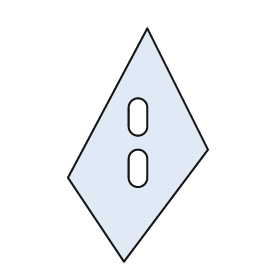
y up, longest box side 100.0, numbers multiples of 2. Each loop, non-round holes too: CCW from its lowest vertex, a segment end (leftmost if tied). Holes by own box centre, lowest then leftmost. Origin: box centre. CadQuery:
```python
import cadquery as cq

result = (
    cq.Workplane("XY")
    .moveTo(-6.0, -50.0)
    .lineTo(30.0, -2.0)
    .lineTo(4.0, 50.0)
    .lineTo(-30.0, -14.0)
    .close()
    .moveTo(-4.0, -14.0)
    .threePointArc((0.0, -18.0), (4.0, -14.0))
    .lineTo(4.0, -6.0)
    .threePointArc((0.0, -2.0), (-4.0, -6.0))
    .close()
    .moveTo(-4.0, 8.0)
    .threePointArc((0.0, 4.0), (4.0, 8.0))
    .lineTo(4.0, 16.0)
    .threePointArc((0.0, 20.0), (-4.0, 16.0))
    .close()
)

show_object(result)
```